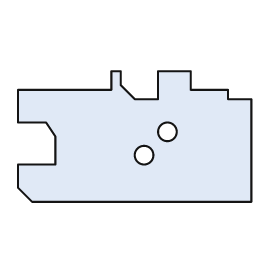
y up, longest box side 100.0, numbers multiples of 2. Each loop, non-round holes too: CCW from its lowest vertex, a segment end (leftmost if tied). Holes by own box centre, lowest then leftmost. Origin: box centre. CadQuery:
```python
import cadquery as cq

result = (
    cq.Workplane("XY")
    .moveTo(-44.0, -28.0)
    .lineTo(50.0, -28.0)
    .lineTo(50.0, 16.0)
    .lineTo(40.0, 16.0)
    .lineTo(40.0, 20.0)
    .lineTo(24.0, 20.0)
    .lineTo(24.0, 28.0)
    .lineTo(10.0, 28.0)
    .lineTo(10.0, 16.0)
    .lineTo(0.0, 16.0)
    .lineTo(-6.0, 22.0)
    .lineTo(-6.0, 28.0)
    .lineTo(-10.0, 28.0)
    .lineTo(-10.0, 20.0)
    .lineTo(-50.0, 20.0)
    .lineTo(-50.0, 6.0)
    .lineTo(-38.0, 6.0)
    .lineTo(-34.0, 0.0)
    .lineTo(-34.0, -12.0)
    .lineTo(-50.0, -12.0)
    .lineTo(-50.0, -22.0)
    .close()
    .moveTo(4.0, -8.0)
    .circle(4.0)
    .moveTo(14.0, 2.0)
    .circle(4.0)
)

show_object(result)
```